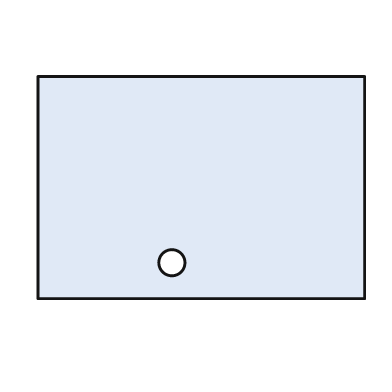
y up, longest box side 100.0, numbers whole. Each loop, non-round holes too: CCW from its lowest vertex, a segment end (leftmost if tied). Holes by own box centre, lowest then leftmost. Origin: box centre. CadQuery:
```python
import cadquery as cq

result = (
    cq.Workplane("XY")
    .moveTo(-50.0, -34.0)
    .lineTo(50.0, -34.0)
    .lineTo(50.0, 34.0)
    .lineTo(-50.0, 34.0)
    .close()
    .moveTo(-9.0, -23.0)
    .circle(4.0)
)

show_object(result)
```